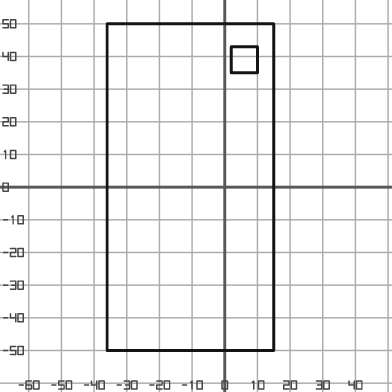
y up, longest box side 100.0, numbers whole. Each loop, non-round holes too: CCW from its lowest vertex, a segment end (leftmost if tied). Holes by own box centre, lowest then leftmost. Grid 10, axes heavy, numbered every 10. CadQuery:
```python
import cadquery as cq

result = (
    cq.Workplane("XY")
    .moveTo(-36.0, -50.0)
    .lineTo(15.0, -50.0)
    .lineTo(15.0, 50.0)
    .lineTo(-36.0, 50.0)
    .close()
    .moveTo(2.0, 35.0)
    .lineTo(10.0, 35.0)
    .lineTo(10.0, 43.0)
    .lineTo(2.0, 43.0)
    .close()
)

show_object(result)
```